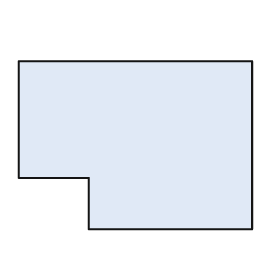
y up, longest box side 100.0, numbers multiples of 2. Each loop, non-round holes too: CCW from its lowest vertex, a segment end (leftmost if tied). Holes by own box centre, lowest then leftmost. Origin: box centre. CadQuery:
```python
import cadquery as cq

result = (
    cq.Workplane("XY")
    .moveTo(-20.0, -36.0)
    .lineTo(50.0, -36.0)
    .lineTo(50.0, 36.0)
    .lineTo(-50.0, 36.0)
    .lineTo(-50.0, -14.0)
    .lineTo(-20.0, -14.0)
    .close()
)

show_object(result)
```